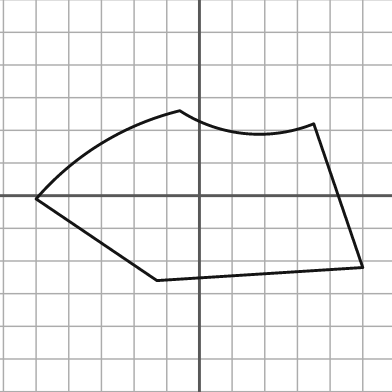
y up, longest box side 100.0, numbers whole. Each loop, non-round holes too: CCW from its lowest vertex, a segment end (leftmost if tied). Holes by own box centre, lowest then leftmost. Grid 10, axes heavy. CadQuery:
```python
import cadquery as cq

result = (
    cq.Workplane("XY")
    .moveTo(-13.0, -26.0)
    .lineTo(50.0, -22.0)
    .lineTo(35.0, 22.0)
    .threePointArc((14.0, 19.0), (-6.0, 26.0))
    .threePointArc((-30.0, 16.0), (-50.0, -1.0))
    .close()
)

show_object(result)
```